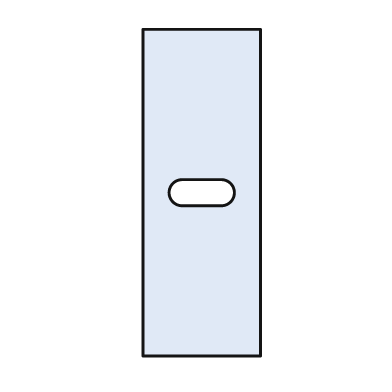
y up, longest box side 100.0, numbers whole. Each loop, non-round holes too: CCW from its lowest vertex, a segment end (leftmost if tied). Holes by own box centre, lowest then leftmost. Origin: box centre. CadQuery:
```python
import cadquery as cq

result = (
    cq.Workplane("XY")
    .moveTo(-18.0, -50.0)
    .lineTo(18.0, -50.0)
    .lineTo(18.0, 50.0)
    .lineTo(-18.0, 50.0)
    .close()
    .moveTo(-6.0, -4.0)
    .lineTo(6.0, -4.0)
    .threePointArc((10.0, 0.0), (6.0, 4.0))
    .lineTo(-6.0, 4.0)
    .threePointArc((-10.0, 0.0), (-6.0, -4.0))
    .close()
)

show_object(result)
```